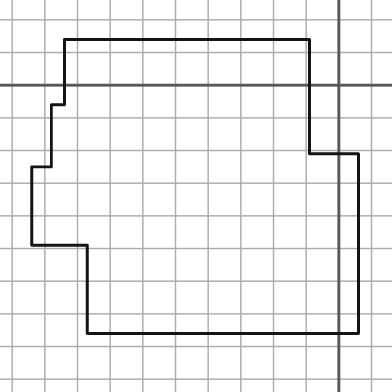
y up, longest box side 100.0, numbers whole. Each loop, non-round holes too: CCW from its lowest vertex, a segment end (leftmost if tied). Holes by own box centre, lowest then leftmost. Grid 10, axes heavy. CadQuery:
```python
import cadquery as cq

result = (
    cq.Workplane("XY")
    .moveTo(-77.0, -76.0)
    .lineTo(6.0, -76.0)
    .lineTo(6.0, -21.0)
    .lineTo(-9.0, -21.0)
    .lineTo(-9.0, 14.0)
    .lineTo(-84.0, 14.0)
    .lineTo(-84.0, -6.0)
    .lineTo(-88.0, -6.0)
    .lineTo(-88.0, -25.0)
    .lineTo(-94.0, -25.0)
    .lineTo(-94.0, -49.0)
    .lineTo(-77.0, -49.0)
    .close()
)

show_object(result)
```